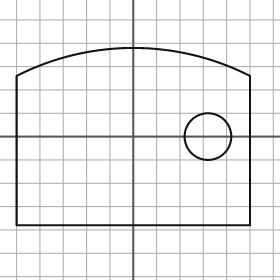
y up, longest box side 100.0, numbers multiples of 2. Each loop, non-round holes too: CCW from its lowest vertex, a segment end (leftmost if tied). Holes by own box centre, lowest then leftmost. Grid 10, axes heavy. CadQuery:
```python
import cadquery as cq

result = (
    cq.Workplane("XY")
    .moveTo(-50.0, -38.0)
    .lineTo(50.0, -38.0)
    .lineTo(50.0, 26.0)
    .threePointArc((0.0, 38.0), (-50.0, 26.0))
    .close()
    .moveTo(32.0, 0.0)
    .circle(10.0)
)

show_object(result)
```